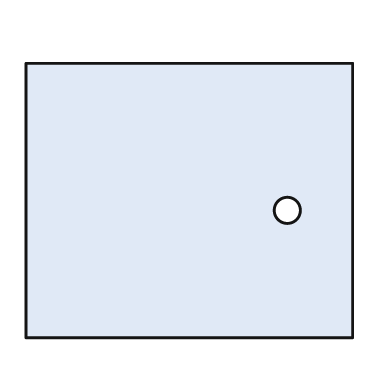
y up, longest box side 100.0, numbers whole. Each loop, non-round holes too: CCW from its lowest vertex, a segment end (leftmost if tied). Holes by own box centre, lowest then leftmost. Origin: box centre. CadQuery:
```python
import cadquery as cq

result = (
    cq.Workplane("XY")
    .moveTo(-50.0, -42.0)
    .lineTo(50.0, -42.0)
    .lineTo(50.0, 42.0)
    .lineTo(-50.0, 42.0)
    .close()
    .moveTo(30.0, -3.0)
    .circle(4.0)
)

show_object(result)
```